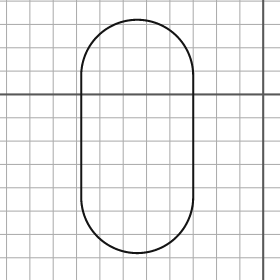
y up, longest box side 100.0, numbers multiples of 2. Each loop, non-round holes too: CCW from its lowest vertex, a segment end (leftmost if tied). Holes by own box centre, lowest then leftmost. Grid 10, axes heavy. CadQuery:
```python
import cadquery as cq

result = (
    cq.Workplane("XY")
    .moveTo(-78.0, -44.0)
    .threePointArc((-54.0, -68.0), (-30.0, -44.0))
    .lineTo(-30.0, 8.0)
    .threePointArc((-54.0, 32.0), (-78.0, 8.0))
    .close()
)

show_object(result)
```